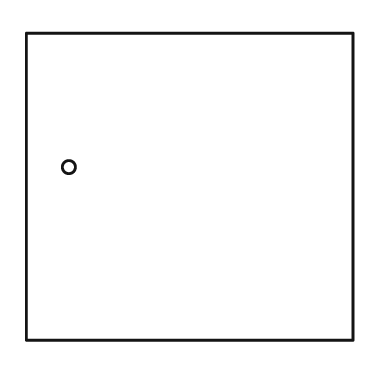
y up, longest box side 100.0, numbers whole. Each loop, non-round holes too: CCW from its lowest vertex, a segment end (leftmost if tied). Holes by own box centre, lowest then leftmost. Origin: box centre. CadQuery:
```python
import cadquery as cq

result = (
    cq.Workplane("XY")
    .moveTo(-50.0, -47.0)
    .lineTo(50.0, -47.0)
    .lineTo(50.0, 47.0)
    .lineTo(-50.0, 47.0)
    .close()
    .moveTo(-37.0, 6.0)
    .circle(2.0)
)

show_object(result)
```